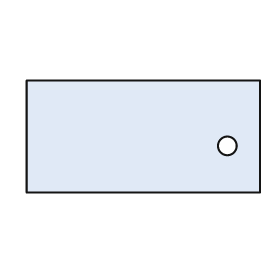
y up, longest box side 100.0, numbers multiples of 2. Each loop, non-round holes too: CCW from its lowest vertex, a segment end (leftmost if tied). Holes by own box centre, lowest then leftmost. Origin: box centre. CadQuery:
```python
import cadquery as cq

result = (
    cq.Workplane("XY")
    .moveTo(-50.0, -24.0)
    .lineTo(50.0, -24.0)
    .lineTo(50.0, 24.0)
    .lineTo(-50.0, 24.0)
    .close()
    .moveTo(36.0, -4.0)
    .circle(4.0)
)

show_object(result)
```